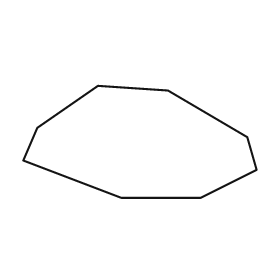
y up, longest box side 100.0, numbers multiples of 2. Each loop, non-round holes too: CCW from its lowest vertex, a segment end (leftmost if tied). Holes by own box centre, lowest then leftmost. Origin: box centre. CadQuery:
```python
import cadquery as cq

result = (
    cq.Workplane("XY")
    .moveTo(-8.0, -24.0)
    .lineTo(26.0, -24.0)
    .lineTo(50.0, -12.0)
    .lineTo(46.0, 2.0)
    .lineTo(12.0, 22.0)
    .lineTo(-18.0, 24.0)
    .lineTo(-44.0, 6.0)
    .lineTo(-50.0, -8.0)
    .close()
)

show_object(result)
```